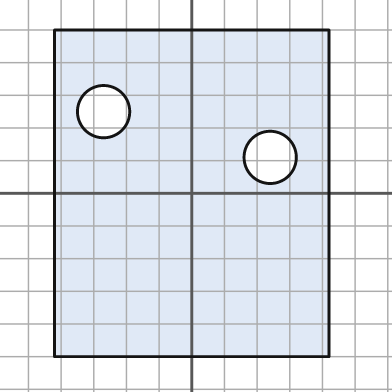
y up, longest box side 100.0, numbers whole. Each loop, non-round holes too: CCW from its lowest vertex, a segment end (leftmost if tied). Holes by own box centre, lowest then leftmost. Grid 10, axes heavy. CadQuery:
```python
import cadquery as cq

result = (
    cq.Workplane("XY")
    .moveTo(-42.0, -50.0)
    .lineTo(42.0, -50.0)
    .lineTo(42.0, 50.0)
    .lineTo(-42.0, 50.0)
    .close()
    .moveTo(24.0, 11.0)
    .circle(8.0)
    .moveTo(-27.0, 25.0)
    .circle(8.0)
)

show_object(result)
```